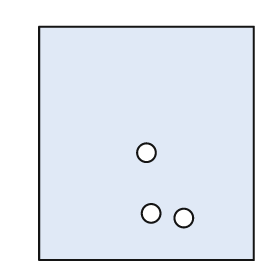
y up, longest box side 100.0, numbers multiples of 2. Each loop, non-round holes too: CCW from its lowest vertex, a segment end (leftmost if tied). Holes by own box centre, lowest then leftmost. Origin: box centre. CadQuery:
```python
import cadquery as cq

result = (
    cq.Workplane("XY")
    .moveTo(-46.0, -50.0)
    .lineTo(46.0, -50.0)
    .lineTo(46.0, 50.0)
    .lineTo(-46.0, 50.0)
    .close()
    .moveTo(16.0, -32.0)
    .circle(4.0)
    .moveTo(2.0, -30.0)
    .circle(4.0)
    .moveTo(0.0, -4.0)
    .circle(4.0)
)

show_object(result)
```